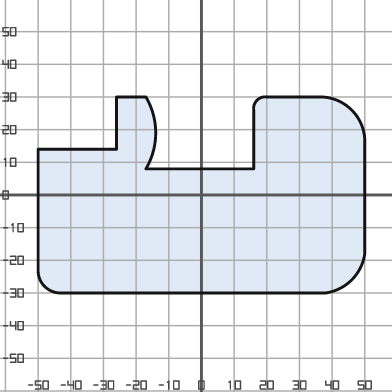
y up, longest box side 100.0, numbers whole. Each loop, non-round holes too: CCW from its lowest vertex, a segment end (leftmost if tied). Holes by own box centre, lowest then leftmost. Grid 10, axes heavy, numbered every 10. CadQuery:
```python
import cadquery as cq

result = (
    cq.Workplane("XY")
    .moveTo(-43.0, -30.0)
    .lineTo(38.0, -30.0)
    .threePointArc((46.0, -26.0), (50.0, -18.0))
    .lineTo(50.0, 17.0)
    .threePointArc((46.0, 26.0), (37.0, 30.0))
    .lineTo(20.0, 30.0)
    .threePointArc((17.0, 29.0), (16.0, 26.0))
    .lineTo(16.0, 8.0)
    .lineTo(-17.0, 8.0)
    .threePointArc((-14.0, 19.0), (-17.0, 30.0))
    .lineTo(-26.0, 30.0)
    .lineTo(-26.0, 14.0)
    .lineTo(-50.0, 14.0)
    .lineTo(-50.0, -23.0)
    .threePointArc((-48.0, -28.0), (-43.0, -30.0))
    .close()
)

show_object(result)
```